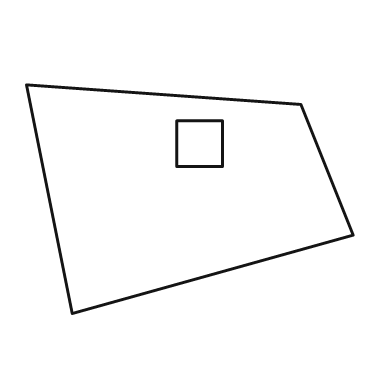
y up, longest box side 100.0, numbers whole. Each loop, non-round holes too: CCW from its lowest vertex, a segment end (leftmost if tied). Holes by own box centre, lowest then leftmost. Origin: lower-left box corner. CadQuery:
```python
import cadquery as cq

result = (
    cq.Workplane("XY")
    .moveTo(14.0, 0.0)
    .lineTo(100.0, 24.0)
    .lineTo(84.0, 64.0)
    .lineTo(0.0, 70.0)
    .close()
    .moveTo(46.0, 45.0)
    .lineTo(60.0, 45.0)
    .lineTo(60.0, 59.0)
    .lineTo(46.0, 59.0)
    .close()
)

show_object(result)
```